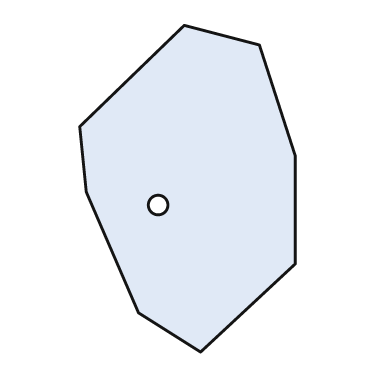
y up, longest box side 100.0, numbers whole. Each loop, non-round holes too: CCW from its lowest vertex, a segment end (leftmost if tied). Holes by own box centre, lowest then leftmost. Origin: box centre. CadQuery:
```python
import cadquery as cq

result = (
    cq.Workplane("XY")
    .moveTo(4.0, -50.0)
    .lineTo(33.0, -23.0)
    .lineTo(33.0, 10.0)
    .lineTo(22.0, 44.0)
    .lineTo(-1.0, 50.0)
    .lineTo(-33.0, 19.0)
    .lineTo(-31.0, -1.0)
    .lineTo(-15.0, -38.0)
    .close()
    .moveTo(-9.0, -5.0)
    .circle(3.0)
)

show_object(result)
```